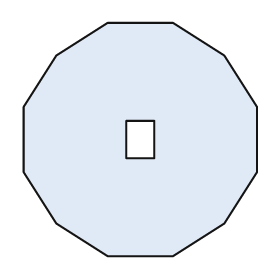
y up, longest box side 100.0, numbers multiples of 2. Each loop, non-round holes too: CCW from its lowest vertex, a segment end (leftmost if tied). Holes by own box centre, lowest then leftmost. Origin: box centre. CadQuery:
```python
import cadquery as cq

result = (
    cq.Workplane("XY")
    .moveTo(-14.0, -50.0)
    .lineTo(14.0, -50.0)
    .lineTo(36.0, -36.0)
    .lineTo(50.0, -14.0)
    .lineTo(50.0, 14.0)
    .lineTo(36.0, 36.0)
    .lineTo(14.0, 50.0)
    .lineTo(-14.0, 50.0)
    .lineTo(-36.0, 36.0)
    .lineTo(-50.0, 14.0)
    .lineTo(-50.0, -14.0)
    .lineTo(-36.0, -36.0)
    .close()
    .moveTo(-6.0, -8.0)
    .lineTo(6.0, -8.0)
    .lineTo(6.0, 8.0)
    .lineTo(-6.0, 8.0)
    .close()
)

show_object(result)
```